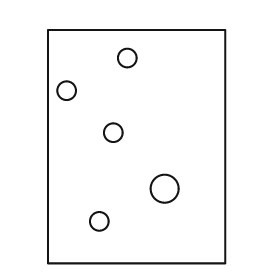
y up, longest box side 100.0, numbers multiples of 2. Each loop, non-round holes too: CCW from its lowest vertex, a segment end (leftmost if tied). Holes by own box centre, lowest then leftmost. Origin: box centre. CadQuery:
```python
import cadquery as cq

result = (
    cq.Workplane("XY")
    .moveTo(-38.0, -50.0)
    .lineTo(38.0, -50.0)
    .lineTo(38.0, 50.0)
    .lineTo(-38.0, 50.0)
    .close()
    .moveTo(-16.0, -32.0)
    .circle(4.0)
    .moveTo(12.0, -18.0)
    .circle(6.0)
    .moveTo(-10.0, 6.0)
    .circle(4.0)
    .moveTo(-30.0, 24.0)
    .circle(4.0)
    .moveTo(-4.0, 38.0)
    .circle(4.0)
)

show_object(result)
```